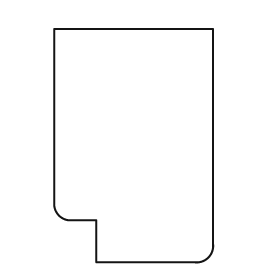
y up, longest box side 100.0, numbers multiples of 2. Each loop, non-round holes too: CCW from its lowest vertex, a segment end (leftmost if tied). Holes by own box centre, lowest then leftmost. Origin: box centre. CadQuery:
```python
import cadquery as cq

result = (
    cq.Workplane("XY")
    .moveTo(-16.0, -50.0)
    .lineTo(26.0, -50.0)
    .threePointArc((32.0, -48.0), (34.0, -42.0))
    .lineTo(34.0, 50.0)
    .lineTo(-34.0, 50.0)
    .lineTo(-34.0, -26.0)
    .threePointArc((-32.0, -30.0), (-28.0, -32.0))
    .lineTo(-16.0, -32.0)
    .close()
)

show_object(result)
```